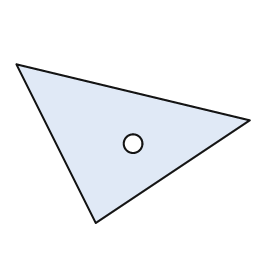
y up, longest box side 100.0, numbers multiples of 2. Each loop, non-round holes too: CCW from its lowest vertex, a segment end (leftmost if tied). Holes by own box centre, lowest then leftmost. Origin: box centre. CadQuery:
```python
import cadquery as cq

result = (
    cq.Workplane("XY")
    .moveTo(-16.0, -34.0)
    .lineTo(50.0, 10.0)
    .lineTo(-50.0, 34.0)
    .close()
    .moveTo(0.0, 0.0)
    .circle(4.0)
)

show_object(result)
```